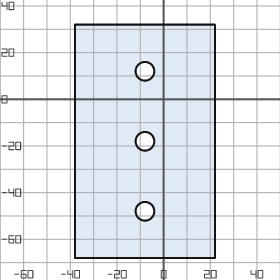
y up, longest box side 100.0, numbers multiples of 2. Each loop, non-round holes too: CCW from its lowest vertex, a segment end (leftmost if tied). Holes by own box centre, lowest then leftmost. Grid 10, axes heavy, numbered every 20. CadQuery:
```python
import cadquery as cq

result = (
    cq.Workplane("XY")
    .moveTo(-38.0, -68.0)
    .lineTo(22.0, -68.0)
    .lineTo(22.0, 32.0)
    .lineTo(-38.0, 32.0)
    .close()
    .moveTo(-8.0, -48.0)
    .circle(4.0)
    .moveTo(-8.0, -18.0)
    .circle(4.0)
    .moveTo(-8.0, 12.0)
    .circle(4.0)
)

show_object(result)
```